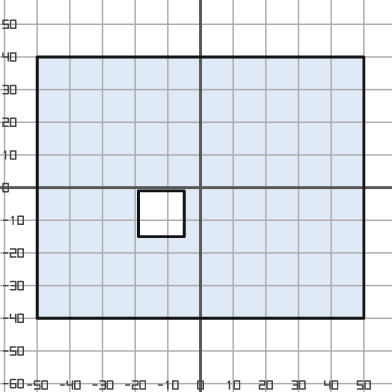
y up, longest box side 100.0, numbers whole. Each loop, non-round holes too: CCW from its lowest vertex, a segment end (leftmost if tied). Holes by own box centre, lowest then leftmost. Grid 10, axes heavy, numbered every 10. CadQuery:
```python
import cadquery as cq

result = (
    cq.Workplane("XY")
    .moveTo(-50.0, -40.0)
    .lineTo(50.0, -40.0)
    .lineTo(50.0, 40.0)
    .lineTo(-50.0, 40.0)
    .close()
    .moveTo(-19.0, -15.0)
    .lineTo(-5.0, -15.0)
    .lineTo(-5.0, -1.0)
    .lineTo(-19.0, -1.0)
    .close()
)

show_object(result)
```